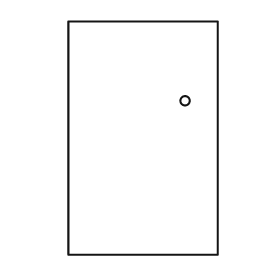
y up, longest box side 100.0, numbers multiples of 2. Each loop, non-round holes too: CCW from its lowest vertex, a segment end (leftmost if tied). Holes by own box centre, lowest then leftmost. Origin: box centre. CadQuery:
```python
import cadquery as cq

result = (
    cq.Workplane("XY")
    .moveTo(-32.0, -50.0)
    .lineTo(32.0, -50.0)
    .lineTo(32.0, 50.0)
    .lineTo(-32.0, 50.0)
    .close()
    .moveTo(18.0, 16.0)
    .circle(2.0)
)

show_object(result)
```